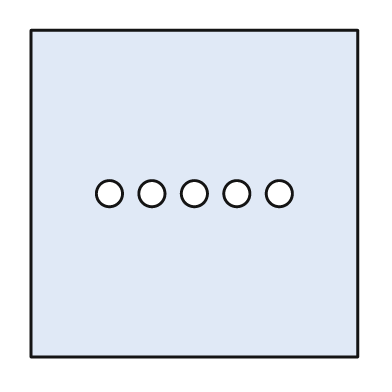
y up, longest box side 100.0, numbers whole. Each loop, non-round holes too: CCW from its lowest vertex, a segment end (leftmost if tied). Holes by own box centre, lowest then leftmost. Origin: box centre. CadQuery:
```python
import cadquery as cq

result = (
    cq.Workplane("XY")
    .moveTo(-50.0, -50.0)
    .lineTo(50.0, -50.0)
    .lineTo(50.0, 50.0)
    .lineTo(-50.0, 50.0)
    .close()
    .moveTo(-26.0, 0.0)
    .circle(4.0)
    .moveTo(-13.0, 0.0)
    .circle(4.0)
    .moveTo(0.0, 0.0)
    .circle(4.0)
    .moveTo(13.0, 0.0)
    .circle(4.0)
    .moveTo(26.0, 0.0)
    .circle(4.0)
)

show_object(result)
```